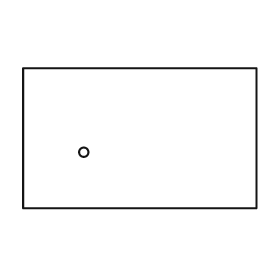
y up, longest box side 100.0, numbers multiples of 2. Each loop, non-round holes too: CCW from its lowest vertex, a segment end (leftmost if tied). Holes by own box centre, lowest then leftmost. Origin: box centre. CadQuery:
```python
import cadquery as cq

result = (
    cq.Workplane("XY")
    .moveTo(-50.0, -30.0)
    .lineTo(50.0, -30.0)
    .lineTo(50.0, 30.0)
    .lineTo(-50.0, 30.0)
    .close()
    .moveTo(-24.0, -6.0)
    .circle(2.0)
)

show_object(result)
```